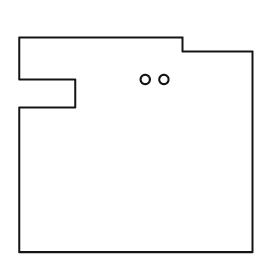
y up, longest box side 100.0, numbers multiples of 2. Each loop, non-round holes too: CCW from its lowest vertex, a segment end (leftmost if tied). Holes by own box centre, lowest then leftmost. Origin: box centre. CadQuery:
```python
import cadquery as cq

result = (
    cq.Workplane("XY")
    .moveTo(-50.0, -46.0)
    .lineTo(50.0, -46.0)
    .lineTo(50.0, 40.0)
    .lineTo(20.0, 40.0)
    .lineTo(20.0, 46.0)
    .lineTo(-50.0, 46.0)
    .lineTo(-50.0, 28.0)
    .lineTo(-26.0, 28.0)
    .lineTo(-26.0, 16.0)
    .lineTo(-50.0, 16.0)
    .close()
    .moveTo(4.0, 28.0)
    .circle(2.0)
    .moveTo(12.0, 28.0)
    .circle(2.0)
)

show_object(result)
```